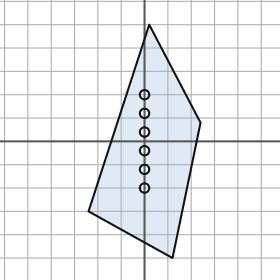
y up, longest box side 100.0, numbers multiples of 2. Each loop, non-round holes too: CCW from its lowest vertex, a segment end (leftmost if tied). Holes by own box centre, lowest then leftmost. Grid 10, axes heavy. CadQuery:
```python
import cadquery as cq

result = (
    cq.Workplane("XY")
    .moveTo(12.0, -50.0)
    .lineTo(24.0, 8.0)
    .lineTo(2.0, 50.0)
    .lineTo(-24.0, -30.0)
    .close()
    .moveTo(0.0, -20.0)
    .circle(2.0)
    .moveTo(0.0, -12.0)
    .circle(2.0)
    .moveTo(0.0, -4.0)
    .circle(2.0)
    .moveTo(0.0, 4.0)
    .circle(2.0)
    .moveTo(0.0, 12.0)
    .circle(2.0)
    .moveTo(0.0, 20.0)
    .circle(2.0)
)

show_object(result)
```